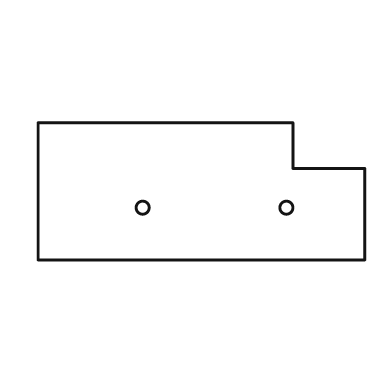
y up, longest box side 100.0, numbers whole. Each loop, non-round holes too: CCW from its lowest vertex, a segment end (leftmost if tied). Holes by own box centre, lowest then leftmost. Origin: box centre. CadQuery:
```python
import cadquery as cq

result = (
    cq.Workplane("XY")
    .moveTo(-50.0, -21.0)
    .lineTo(50.0, -21.0)
    .lineTo(50.0, 7.0)
    .lineTo(28.0, 7.0)
    .lineTo(28.0, 21.0)
    .lineTo(-50.0, 21.0)
    .close()
    .moveTo(-18.0, -5.0)
    .circle(2.0)
    .moveTo(26.0, -5.0)
    .circle(2.0)
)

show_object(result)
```